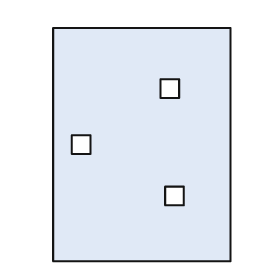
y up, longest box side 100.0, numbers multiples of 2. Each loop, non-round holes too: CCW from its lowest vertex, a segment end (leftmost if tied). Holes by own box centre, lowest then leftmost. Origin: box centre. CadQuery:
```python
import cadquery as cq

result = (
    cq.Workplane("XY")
    .moveTo(-38.0, -50.0)
    .lineTo(38.0, -50.0)
    .lineTo(38.0, 50.0)
    .lineTo(-38.0, 50.0)
    .close()
    .moveTo(10.0, -26.0)
    .lineTo(18.0, -26.0)
    .lineTo(18.0, -18.0)
    .lineTo(10.0, -18.0)
    .close()
    .moveTo(-30.0, -4.0)
    .lineTo(-22.0, -4.0)
    .lineTo(-22.0, 4.0)
    .lineTo(-30.0, 4.0)
    .close()
    .moveTo(8.0, 20.0)
    .lineTo(16.0, 20.0)
    .lineTo(16.0, 28.0)
    .lineTo(8.0, 28.0)
    .close()
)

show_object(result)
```